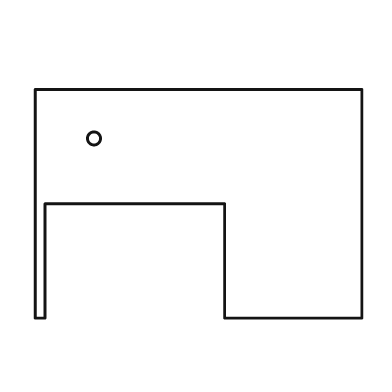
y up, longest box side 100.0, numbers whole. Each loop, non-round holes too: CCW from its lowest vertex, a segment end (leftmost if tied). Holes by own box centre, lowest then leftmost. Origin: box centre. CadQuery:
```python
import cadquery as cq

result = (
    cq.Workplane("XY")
    .moveTo(-50.0, -35.0)
    .lineTo(-47.0, -35.0)
    .lineTo(-47.0, 0.0)
    .lineTo(8.0, 0.0)
    .lineTo(8.0, -35.0)
    .lineTo(50.0, -35.0)
    .lineTo(50.0, 35.0)
    .lineTo(-50.0, 35.0)
    .close()
    .moveTo(-32.0, 20.0)
    .circle(2.0)
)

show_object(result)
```